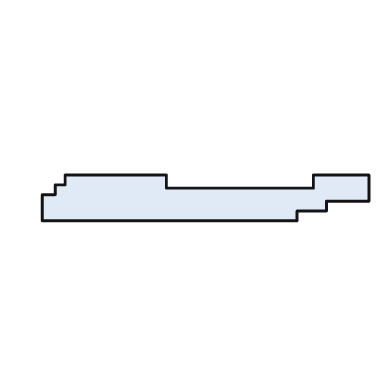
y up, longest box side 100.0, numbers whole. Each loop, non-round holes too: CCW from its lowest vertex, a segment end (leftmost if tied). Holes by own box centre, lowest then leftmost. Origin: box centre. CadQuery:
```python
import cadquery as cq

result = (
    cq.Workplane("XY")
    .moveTo(-50.0, -7.0)
    .lineTo(28.0, -7.0)
    .lineTo(28.0, -4.0)
    .lineTo(37.0, -4.0)
    .lineTo(37.0, -1.0)
    .lineTo(50.0, -1.0)
    .lineTo(50.0, 7.0)
    .lineTo(33.0, 7.0)
    .lineTo(33.0, 3.0)
    .lineTo(-12.0, 3.0)
    .lineTo(-12.0, 7.0)
    .lineTo(-43.0, 7.0)
    .lineTo(-43.0, 4.0)
    .lineTo(-46.0, 4.0)
    .lineTo(-46.0, 1.0)
    .lineTo(-50.0, 1.0)
    .close()
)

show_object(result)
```